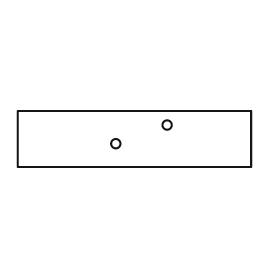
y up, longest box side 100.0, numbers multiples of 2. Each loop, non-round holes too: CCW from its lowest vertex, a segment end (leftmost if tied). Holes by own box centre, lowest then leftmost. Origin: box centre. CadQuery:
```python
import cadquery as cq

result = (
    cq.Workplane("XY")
    .moveTo(-50.0, -12.0)
    .lineTo(50.0, -12.0)
    .lineTo(50.0, 12.0)
    .lineTo(-50.0, 12.0)
    .close()
    .moveTo(-8.0, -2.0)
    .circle(2.0)
    .moveTo(14.0, 6.0)
    .circle(2.0)
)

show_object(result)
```